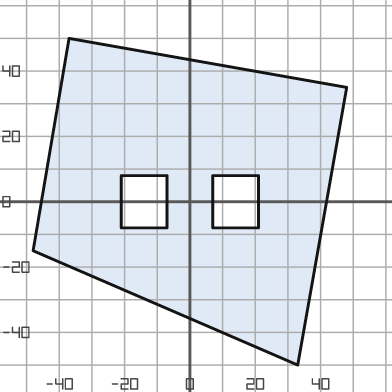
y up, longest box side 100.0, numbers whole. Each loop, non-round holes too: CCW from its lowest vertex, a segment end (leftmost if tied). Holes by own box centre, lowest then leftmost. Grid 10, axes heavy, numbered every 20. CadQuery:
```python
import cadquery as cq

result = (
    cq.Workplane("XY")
    .moveTo(33.0, -50.0)
    .lineTo(48.0, 35.0)
    .lineTo(-37.0, 50.0)
    .lineTo(-48.0, -15.0)
    .close()
    .moveTo(-21.0, -8.0)
    .lineTo(-7.0, -8.0)
    .lineTo(-7.0, 8.0)
    .lineTo(-21.0, 8.0)
    .close()
    .moveTo(7.0, -8.0)
    .lineTo(21.0, -8.0)
    .lineTo(21.0, 8.0)
    .lineTo(7.0, 8.0)
    .close()
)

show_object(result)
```